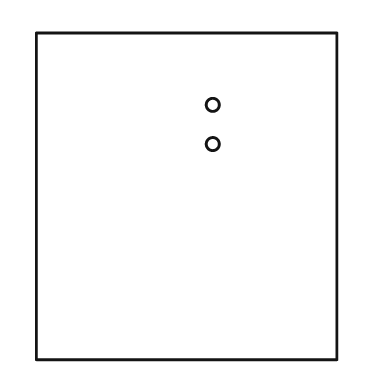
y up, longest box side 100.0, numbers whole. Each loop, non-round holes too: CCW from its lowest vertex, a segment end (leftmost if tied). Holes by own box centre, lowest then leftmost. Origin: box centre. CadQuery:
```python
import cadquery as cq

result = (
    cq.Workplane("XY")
    .moveTo(-46.0, -50.0)
    .lineTo(46.0, -50.0)
    .lineTo(46.0, 50.0)
    .lineTo(-46.0, 50.0)
    .close()
    .moveTo(8.0, 16.0)
    .circle(2.0)
    .moveTo(8.0, 28.0)
    .circle(2.0)
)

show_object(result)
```